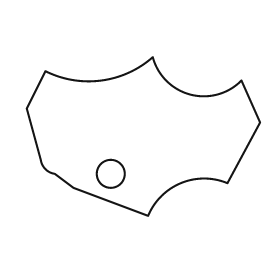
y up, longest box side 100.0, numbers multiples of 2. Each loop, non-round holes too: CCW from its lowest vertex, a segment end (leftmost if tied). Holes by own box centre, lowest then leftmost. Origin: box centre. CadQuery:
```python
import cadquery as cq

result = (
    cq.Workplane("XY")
    .moveTo(2.0, -34.0)
    .threePointArc((16.0, -20.0), (36.0, -20.0))
    .lineTo(50.0, 6.0)
    .lineTo(42.0, 24.0)
    .threePointArc((20.0, 18.0), (4.0, 34.0))
    .threePointArc((-18.0, 24.0), (-42.0, 28.0))
    .lineTo(-50.0, 12.0)
    .lineTo(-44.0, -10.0)
    .threePointArc((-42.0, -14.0), (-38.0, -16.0))
    .lineTo(-30.0, -22.0)
    .close()
    .moveTo(-14.0, -16.0)
    .circle(6.0)
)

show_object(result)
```